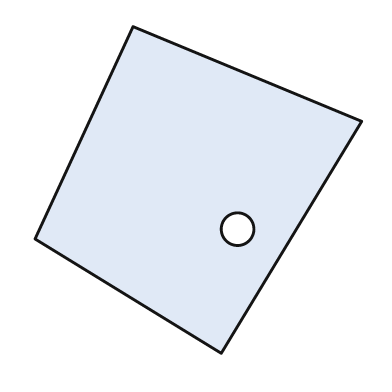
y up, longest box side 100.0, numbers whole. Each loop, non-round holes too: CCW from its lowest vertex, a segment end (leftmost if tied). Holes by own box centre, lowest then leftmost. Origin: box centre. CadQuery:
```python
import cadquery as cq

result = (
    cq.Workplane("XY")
    .moveTo(7.0, -50.0)
    .lineTo(50.0, 21.0)
    .lineTo(-20.0, 50.0)
    .lineTo(-50.0, -15.0)
    .close()
    .moveTo(12.0, -12.0)
    .circle(5.0)
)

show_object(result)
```